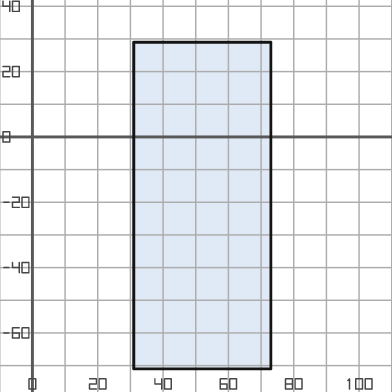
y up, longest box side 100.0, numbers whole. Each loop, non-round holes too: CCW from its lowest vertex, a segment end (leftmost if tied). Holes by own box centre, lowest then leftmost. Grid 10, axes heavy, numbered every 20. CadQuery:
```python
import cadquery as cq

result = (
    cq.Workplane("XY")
    .moveTo(31.0, -71.0)
    .lineTo(73.0, -71.0)
    .lineTo(73.0, 29.0)
    .lineTo(31.0, 29.0)
    .close()
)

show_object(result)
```